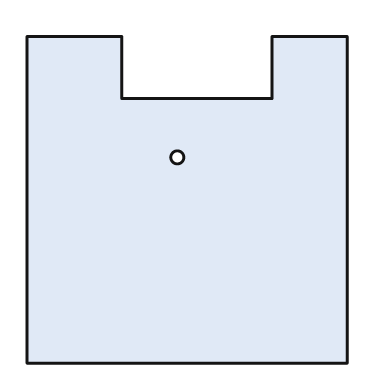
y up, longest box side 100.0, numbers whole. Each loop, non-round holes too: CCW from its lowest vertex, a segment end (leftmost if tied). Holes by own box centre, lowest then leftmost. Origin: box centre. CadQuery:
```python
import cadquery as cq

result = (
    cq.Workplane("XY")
    .moveTo(-49.0, -50.0)
    .lineTo(49.0, -50.0)
    .lineTo(49.0, 50.0)
    .lineTo(26.0, 50.0)
    .lineTo(26.0, 31.0)
    .lineTo(-20.0, 31.0)
    .lineTo(-20.0, 50.0)
    .lineTo(-49.0, 50.0)
    .close()
    .moveTo(-3.0, 13.0)
    .circle(2.0)
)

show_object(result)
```